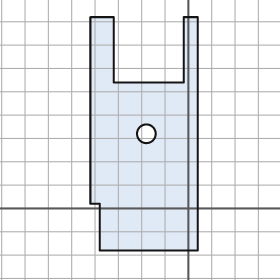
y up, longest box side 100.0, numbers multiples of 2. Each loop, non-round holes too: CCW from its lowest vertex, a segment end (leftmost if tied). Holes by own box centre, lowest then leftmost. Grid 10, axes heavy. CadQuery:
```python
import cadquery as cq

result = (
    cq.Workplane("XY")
    .moveTo(-38.0, -18.0)
    .lineTo(4.0, -18.0)
    .lineTo(4.0, 82.0)
    .lineTo(-2.0, 82.0)
    .lineTo(-2.0, 54.0)
    .lineTo(-32.0, 54.0)
    .lineTo(-32.0, 82.0)
    .lineTo(-42.0, 82.0)
    .lineTo(-42.0, 2.0)
    .lineTo(-38.0, 2.0)
    .close()
    .moveTo(-18.0, 32.0)
    .circle(4.0)
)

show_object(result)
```